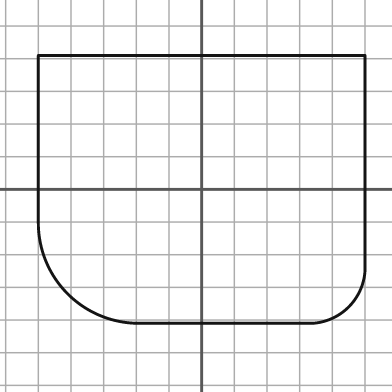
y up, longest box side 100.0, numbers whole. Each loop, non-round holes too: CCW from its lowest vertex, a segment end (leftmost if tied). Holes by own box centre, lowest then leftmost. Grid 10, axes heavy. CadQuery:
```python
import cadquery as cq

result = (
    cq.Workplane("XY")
    .moveTo(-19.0, -41.0)
    .lineTo(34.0, -41.0)
    .threePointArc((45.0, -36.0), (50.0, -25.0))
    .lineTo(50.0, 41.0)
    .lineTo(-50.0, 41.0)
    .lineTo(-50.0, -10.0)
    .threePointArc((-41.0, -32.0), (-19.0, -41.0))
    .close()
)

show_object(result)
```